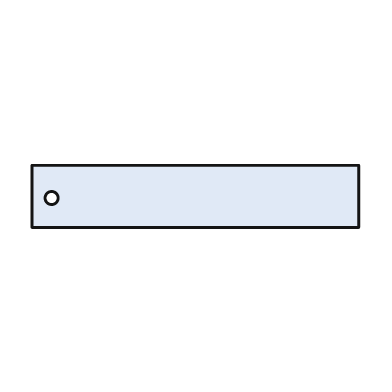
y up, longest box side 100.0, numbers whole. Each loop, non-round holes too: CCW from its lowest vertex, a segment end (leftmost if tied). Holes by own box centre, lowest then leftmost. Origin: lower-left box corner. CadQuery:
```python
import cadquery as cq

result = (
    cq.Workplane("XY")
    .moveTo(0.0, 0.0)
    .lineTo(100.0, 0.0)
    .lineTo(100.0, 19.0)
    .lineTo(0.0, 19.0)
    .close()
    .moveTo(6.0, 9.0)
    .circle(2.0)
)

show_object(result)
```